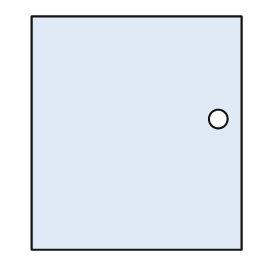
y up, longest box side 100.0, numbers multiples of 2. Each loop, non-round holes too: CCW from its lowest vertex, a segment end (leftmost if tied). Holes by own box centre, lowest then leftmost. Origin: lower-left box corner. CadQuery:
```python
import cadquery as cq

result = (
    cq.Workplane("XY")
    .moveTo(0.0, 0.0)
    .lineTo(90.0, 0.0)
    .lineTo(90.0, 100.0)
    .lineTo(0.0, 100.0)
    .close()
    .moveTo(80.0, 56.0)
    .circle(4.0)
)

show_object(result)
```